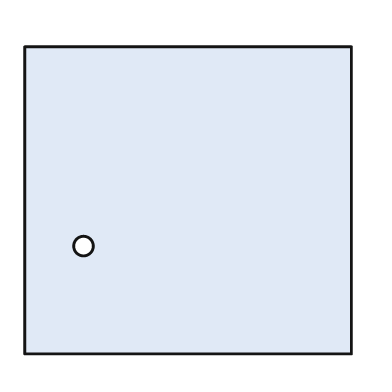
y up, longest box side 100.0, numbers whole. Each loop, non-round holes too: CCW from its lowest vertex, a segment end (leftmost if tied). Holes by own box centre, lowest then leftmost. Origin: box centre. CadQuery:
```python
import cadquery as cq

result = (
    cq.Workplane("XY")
    .moveTo(-50.0, -47.0)
    .lineTo(50.0, -47.0)
    .lineTo(50.0, 47.0)
    .lineTo(-50.0, 47.0)
    .close()
    .moveTo(-32.0, -14.0)
    .circle(3.0)
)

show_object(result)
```